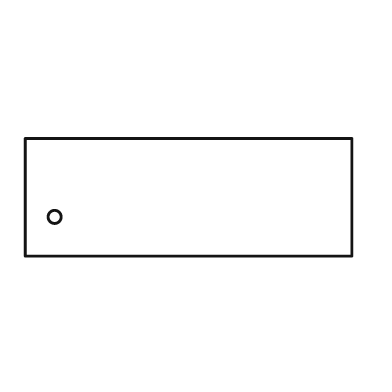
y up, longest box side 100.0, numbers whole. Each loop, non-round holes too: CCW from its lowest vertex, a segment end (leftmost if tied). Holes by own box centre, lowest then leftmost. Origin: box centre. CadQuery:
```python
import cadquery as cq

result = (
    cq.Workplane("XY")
    .moveTo(-50.0, -18.0)
    .lineTo(50.0, -18.0)
    .lineTo(50.0, 18.0)
    .lineTo(-50.0, 18.0)
    .close()
    .moveTo(-41.0, -6.0)
    .circle(2.0)
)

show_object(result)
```